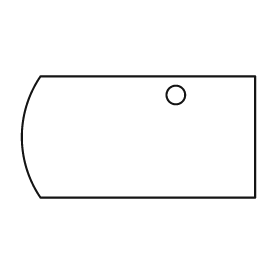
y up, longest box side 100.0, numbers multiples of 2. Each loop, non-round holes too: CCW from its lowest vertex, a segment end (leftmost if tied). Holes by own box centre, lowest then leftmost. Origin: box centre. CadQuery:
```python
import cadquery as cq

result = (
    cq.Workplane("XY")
    .moveTo(-42.0, -26.0)
    .lineTo(50.0, -26.0)
    .lineTo(50.0, 26.0)
    .lineTo(-42.0, 26.0)
    .threePointArc((-50.0, 0.0), (-42.0, -26.0))
    .close()
    .moveTo(16.0, 18.0)
    .circle(4.0)
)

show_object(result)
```